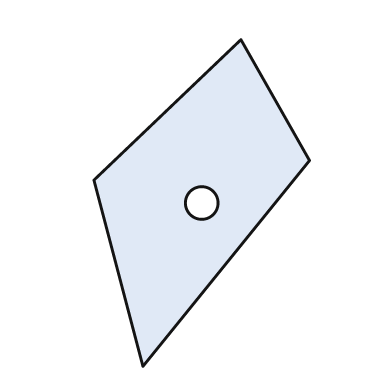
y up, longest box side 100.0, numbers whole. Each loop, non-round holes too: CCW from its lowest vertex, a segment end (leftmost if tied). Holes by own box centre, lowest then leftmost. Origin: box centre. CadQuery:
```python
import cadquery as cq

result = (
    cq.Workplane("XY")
    .moveTo(-18.0, -50.0)
    .lineTo(33.0, 13.0)
    .lineTo(12.0, 50.0)
    .lineTo(-33.0, 7.0)
    .close()
    .moveTo(0.0, 0.0)
    .circle(5.0)
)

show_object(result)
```